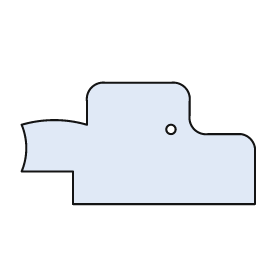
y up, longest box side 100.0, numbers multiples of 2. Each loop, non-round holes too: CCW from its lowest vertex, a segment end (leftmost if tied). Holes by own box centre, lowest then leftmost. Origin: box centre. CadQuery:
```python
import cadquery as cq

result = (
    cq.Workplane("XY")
    .moveTo(-28.0, -26.0)
    .lineTo(50.0, -26.0)
    .lineTo(50.0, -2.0)
    .threePointArc((48.0, 2.0), (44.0, 4.0))
    .lineTo(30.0, 4.0)
    .threePointArc((24.0, 6.0), (22.0, 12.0))
    .lineTo(22.0, 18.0)
    .threePointArc((20.0, 24.0), (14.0, 26.0))
    .lineTo(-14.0, 26.0)
    .threePointArc((-20.0, 24.0), (-22.0, 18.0))
    .lineTo(-22.0, 8.0)
    .threePointArc((-36.0, 10.0), (-50.0, 8.0))
    .threePointArc((-48.0, -2.0), (-50.0, -12.0))
    .lineTo(-28.0, -12.0)
    .close()
    .moveTo(14.0, 6.0)
    .circle(2.0)
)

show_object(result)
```